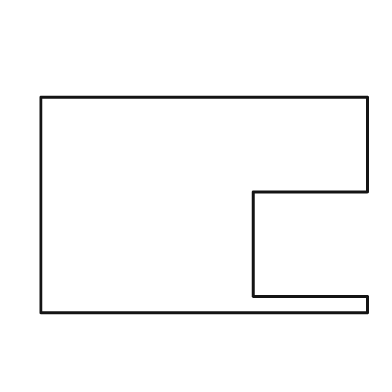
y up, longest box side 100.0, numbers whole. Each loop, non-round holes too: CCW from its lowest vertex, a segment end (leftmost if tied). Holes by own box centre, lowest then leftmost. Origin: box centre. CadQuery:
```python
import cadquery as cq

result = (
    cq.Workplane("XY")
    .moveTo(-50.0, -33.0)
    .lineTo(50.0, -33.0)
    .lineTo(50.0, -28.0)
    .lineTo(15.0, -28.0)
    .lineTo(15.0, 4.0)
    .lineTo(50.0, 4.0)
    .lineTo(50.0, 33.0)
    .lineTo(-50.0, 33.0)
    .close()
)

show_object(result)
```